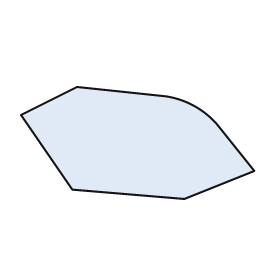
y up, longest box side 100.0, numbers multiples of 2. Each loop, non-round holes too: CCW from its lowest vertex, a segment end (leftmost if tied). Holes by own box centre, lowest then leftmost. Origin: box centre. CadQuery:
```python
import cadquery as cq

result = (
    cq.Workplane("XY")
    .moveTo(20.0, -24.0)
    .lineTo(50.0, -12.0)
    .lineTo(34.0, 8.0)
    .threePointArc((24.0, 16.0), (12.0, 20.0))
    .lineTo(-26.0, 24.0)
    .lineTo(-50.0, 12.0)
    .lineTo(-28.0, -20.0)
    .close()
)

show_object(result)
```